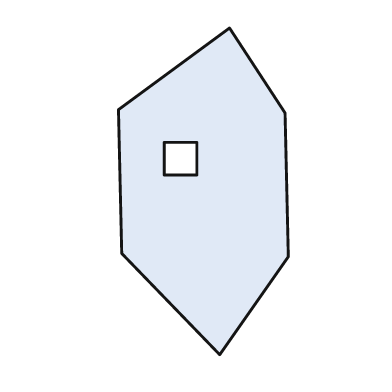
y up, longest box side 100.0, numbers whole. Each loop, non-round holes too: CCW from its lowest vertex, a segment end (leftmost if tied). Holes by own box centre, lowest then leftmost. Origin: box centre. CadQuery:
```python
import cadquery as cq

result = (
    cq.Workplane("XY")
    .moveTo(5.0, -50.0)
    .lineTo(26.0, -20.0)
    .lineTo(25.0, 24.0)
    .lineTo(8.0, 50.0)
    .lineTo(-26.0, 25.0)
    .lineTo(-25.0, -19.0)
    .close()
    .moveTo(-12.0, 5.0)
    .lineTo(-2.0, 5.0)
    .lineTo(-2.0, 15.0)
    .lineTo(-12.0, 15.0)
    .close()
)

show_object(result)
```